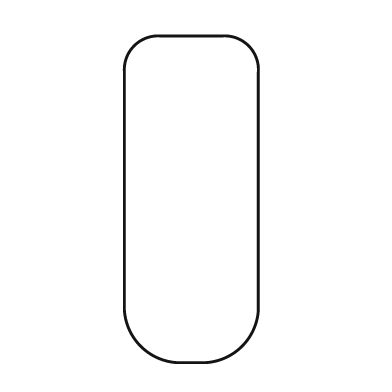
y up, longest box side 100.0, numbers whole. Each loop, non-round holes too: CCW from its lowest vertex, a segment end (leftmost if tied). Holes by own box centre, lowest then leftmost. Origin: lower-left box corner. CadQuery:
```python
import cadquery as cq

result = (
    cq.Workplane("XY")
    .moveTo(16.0, 0.0)
    .lineTo(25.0, 0.0)
    .threePointArc((36.0, 5.0), (41.0, 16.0))
    .lineTo(41.0, 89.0)
    .threePointArc((38.0, 97.0), (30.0, 100.0))
    .lineTo(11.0, 100.0)
    .threePointArc((3.0, 97.0), (0.0, 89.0))
    .lineTo(0.0, 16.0)
    .threePointArc((5.0, 5.0), (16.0, 0.0))
    .close()
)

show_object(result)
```